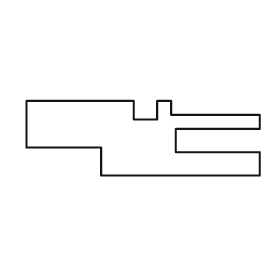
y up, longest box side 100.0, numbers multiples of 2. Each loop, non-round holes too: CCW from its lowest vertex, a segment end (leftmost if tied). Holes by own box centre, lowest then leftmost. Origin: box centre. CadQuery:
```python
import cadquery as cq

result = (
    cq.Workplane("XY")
    .moveTo(-18.0, -16.0)
    .lineTo(50.0, -16.0)
    .lineTo(50.0, -6.0)
    .lineTo(14.0, -6.0)
    .lineTo(14.0, 4.0)
    .lineTo(50.0, 4.0)
    .lineTo(50.0, 10.0)
    .lineTo(12.0, 10.0)
    .lineTo(12.0, 16.0)
    .lineTo(6.0, 16.0)
    .lineTo(6.0, 8.0)
    .lineTo(-4.0, 8.0)
    .lineTo(-4.0, 16.0)
    .lineTo(-50.0, 16.0)
    .lineTo(-50.0, -4.0)
    .lineTo(-18.0, -4.0)
    .close()
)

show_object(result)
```